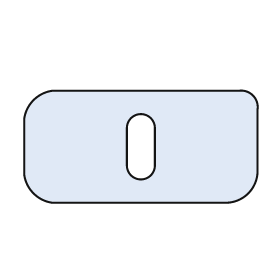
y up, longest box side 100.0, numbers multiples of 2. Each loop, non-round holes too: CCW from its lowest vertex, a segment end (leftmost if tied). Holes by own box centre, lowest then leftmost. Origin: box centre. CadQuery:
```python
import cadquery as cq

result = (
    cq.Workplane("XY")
    .moveTo(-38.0, -24.0)
    .lineTo(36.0, -24.0)
    .threePointArc((46.0, -20.0), (50.0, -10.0))
    .lineTo(50.0, 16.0)
    .threePointArc((48.0, 22.0), (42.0, 24.0))
    .lineTo(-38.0, 24.0)
    .threePointArc((-46.0, 20.0), (-50.0, 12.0))
    .lineTo(-50.0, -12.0)
    .threePointArc((-46.0, -20.0), (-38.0, -24.0))
    .close()
    .moveTo(-6.0, -8.0)
    .threePointArc((0.0, -14.0), (6.0, -8.0))
    .lineTo(6.0, 8.0)
    .threePointArc((0.0, 14.0), (-6.0, 8.0))
    .close()
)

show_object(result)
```